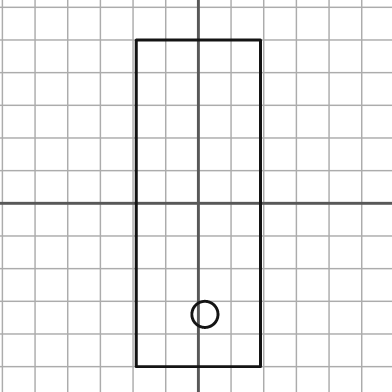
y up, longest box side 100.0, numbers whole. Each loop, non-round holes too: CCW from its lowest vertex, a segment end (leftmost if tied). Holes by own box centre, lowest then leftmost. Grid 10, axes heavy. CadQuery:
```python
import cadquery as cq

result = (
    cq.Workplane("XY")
    .moveTo(-19.0, -50.0)
    .lineTo(19.0, -50.0)
    .lineTo(19.0, 50.0)
    .lineTo(-19.0, 50.0)
    .close()
    .moveTo(2.0, -34.0)
    .circle(4.0)
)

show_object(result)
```